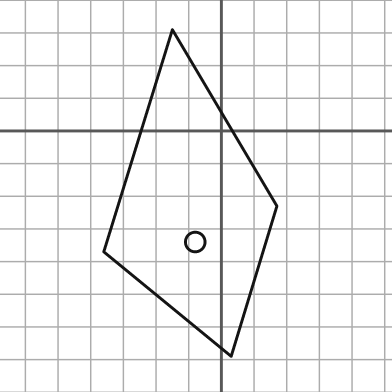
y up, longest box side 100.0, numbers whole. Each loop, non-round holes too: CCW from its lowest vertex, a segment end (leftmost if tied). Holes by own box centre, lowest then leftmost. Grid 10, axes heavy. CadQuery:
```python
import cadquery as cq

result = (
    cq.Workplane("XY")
    .moveTo(3.0, -69.0)
    .lineTo(17.0, -23.0)
    .lineTo(-15.0, 31.0)
    .lineTo(-36.0, -37.0)
    .close()
    .moveTo(-8.0, -34.0)
    .circle(3.0)
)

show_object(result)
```